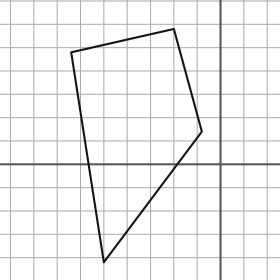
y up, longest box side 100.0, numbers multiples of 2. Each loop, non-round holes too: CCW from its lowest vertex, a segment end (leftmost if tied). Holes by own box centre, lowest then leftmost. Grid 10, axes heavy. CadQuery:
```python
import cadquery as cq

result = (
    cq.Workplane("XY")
    .moveTo(-50.0, -42.0)
    .lineTo(-8.0, 14.0)
    .lineTo(-20.0, 58.0)
    .lineTo(-64.0, 48.0)
    .close()
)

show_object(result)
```